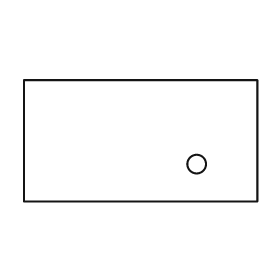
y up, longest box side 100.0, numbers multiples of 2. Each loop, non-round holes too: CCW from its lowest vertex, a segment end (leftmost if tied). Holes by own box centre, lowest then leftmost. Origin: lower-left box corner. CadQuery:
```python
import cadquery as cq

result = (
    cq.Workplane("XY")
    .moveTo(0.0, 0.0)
    .lineTo(100.0, 0.0)
    .lineTo(100.0, 52.0)
    .lineTo(0.0, 52.0)
    .close()
    .moveTo(74.0, 16.0)
    .circle(4.0)
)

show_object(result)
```